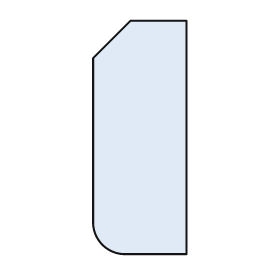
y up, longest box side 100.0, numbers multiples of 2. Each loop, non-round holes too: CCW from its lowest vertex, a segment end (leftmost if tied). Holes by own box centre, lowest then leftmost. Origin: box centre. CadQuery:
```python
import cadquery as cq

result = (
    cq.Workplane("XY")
    .moveTo(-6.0, -50.0)
    .lineTo(20.0, -50.0)
    .lineTo(20.0, 50.0)
    .lineTo(-4.0, 50.0)
    .lineTo(-20.0, 34.0)
    .lineTo(-20.0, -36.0)
    .threePointArc((-16.0, -46.0), (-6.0, -50.0))
    .close()
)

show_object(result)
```